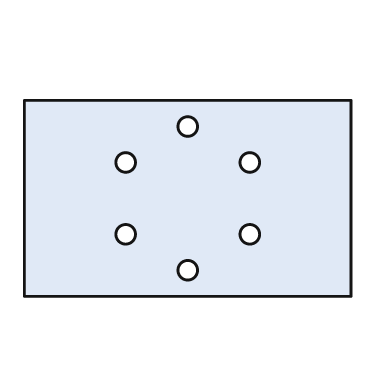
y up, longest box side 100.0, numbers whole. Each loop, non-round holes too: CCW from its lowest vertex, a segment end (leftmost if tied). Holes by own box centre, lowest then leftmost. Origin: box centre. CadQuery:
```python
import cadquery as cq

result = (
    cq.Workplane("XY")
    .moveTo(-50.0, -30.0)
    .lineTo(50.0, -30.0)
    .lineTo(50.0, 30.0)
    .lineTo(-50.0, 30.0)
    .close()
    .moveTo(0.0, -22.0)
    .circle(3.0)
    .moveTo(-19.0, -11.0)
    .circle(3.0)
    .moveTo(19.0, -11.0)
    .circle(3.0)
    .moveTo(-19.0, 11.0)
    .circle(3.0)
    .moveTo(19.0, 11.0)
    .circle(3.0)
    .moveTo(0.0, 22.0)
    .circle(3.0)
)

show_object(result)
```